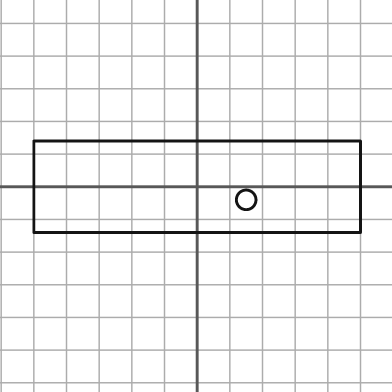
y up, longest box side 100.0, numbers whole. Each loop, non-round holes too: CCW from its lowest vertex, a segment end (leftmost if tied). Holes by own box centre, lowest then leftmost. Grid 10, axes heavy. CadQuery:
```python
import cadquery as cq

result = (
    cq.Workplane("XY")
    .moveTo(-50.0, -14.0)
    .lineTo(50.0, -14.0)
    .lineTo(50.0, 14.0)
    .lineTo(-50.0, 14.0)
    .close()
    .moveTo(15.0, -4.0)
    .circle(3.0)
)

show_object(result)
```